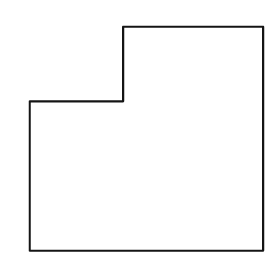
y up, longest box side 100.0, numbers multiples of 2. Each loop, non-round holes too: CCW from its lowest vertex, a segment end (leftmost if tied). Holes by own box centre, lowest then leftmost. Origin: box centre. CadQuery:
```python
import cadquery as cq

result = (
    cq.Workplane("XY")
    .moveTo(-50.0, -48.0)
    .lineTo(50.0, -48.0)
    .lineTo(50.0, 48.0)
    .lineTo(-10.0, 48.0)
    .lineTo(-10.0, 16.0)
    .lineTo(-50.0, 16.0)
    .close()
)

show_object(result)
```